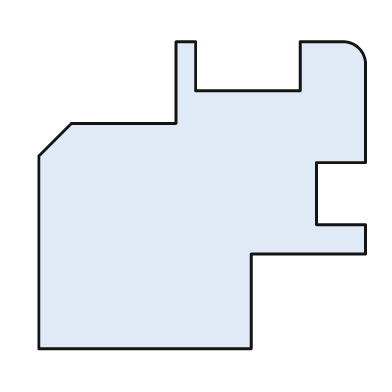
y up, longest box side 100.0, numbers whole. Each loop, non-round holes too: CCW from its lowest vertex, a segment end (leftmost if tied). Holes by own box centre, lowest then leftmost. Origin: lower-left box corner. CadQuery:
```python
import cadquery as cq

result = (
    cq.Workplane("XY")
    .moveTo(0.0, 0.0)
    .lineTo(65.0, 0.0)
    .lineTo(65.0, 29.0)
    .lineTo(100.0, 29.0)
    .lineTo(100.0, 38.0)
    .lineTo(85.0, 38.0)
    .lineTo(85.0, 57.0)
    .lineTo(100.0, 57.0)
    .lineTo(100.0, 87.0)
    .threePointArc((98.0, 92.0), (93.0, 94.0))
    .lineTo(80.0, 94.0)
    .lineTo(80.0, 79.0)
    .lineTo(48.0, 79.0)
    .lineTo(48.0, 94.0)
    .lineTo(42.0, 94.0)
    .lineTo(42.0, 69.0)
    .lineTo(10.0, 69.0)
    .lineTo(0.0, 59.0)
    .close()
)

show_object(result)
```